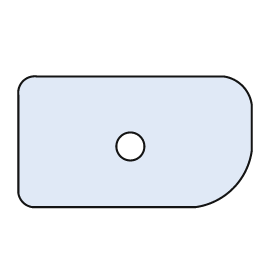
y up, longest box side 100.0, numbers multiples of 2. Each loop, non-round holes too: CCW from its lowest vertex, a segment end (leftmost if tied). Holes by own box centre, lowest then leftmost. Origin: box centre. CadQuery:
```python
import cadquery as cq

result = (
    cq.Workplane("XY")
    .moveTo(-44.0, -28.0)
    .lineTo(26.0, -28.0)
    .threePointArc((42.0, -20.0), (50.0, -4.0))
    .lineTo(50.0, 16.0)
    .threePointArc((46.0, 24.0), (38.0, 28.0))
    .lineTo(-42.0, 28.0)
    .threePointArc((-48.0, 26.0), (-50.0, 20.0))
    .lineTo(-50.0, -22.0)
    .threePointArc((-48.0, -26.0), (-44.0, -28.0))
    .close()
    .moveTo(-2.0, -2.0)
    .circle(6.0)
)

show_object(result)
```